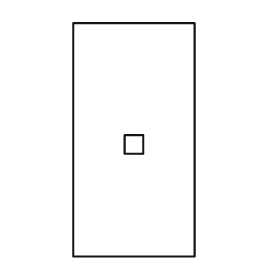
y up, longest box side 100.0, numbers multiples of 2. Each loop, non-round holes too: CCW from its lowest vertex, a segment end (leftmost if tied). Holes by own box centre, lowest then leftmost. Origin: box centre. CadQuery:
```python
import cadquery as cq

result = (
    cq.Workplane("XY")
    .moveTo(-26.0, -50.0)
    .lineTo(26.0, -50.0)
    .lineTo(26.0, 50.0)
    .lineTo(-26.0, 50.0)
    .close()
    .moveTo(-4.0, -6.0)
    .lineTo(4.0, -6.0)
    .lineTo(4.0, 2.0)
    .lineTo(-4.0, 2.0)
    .close()
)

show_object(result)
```